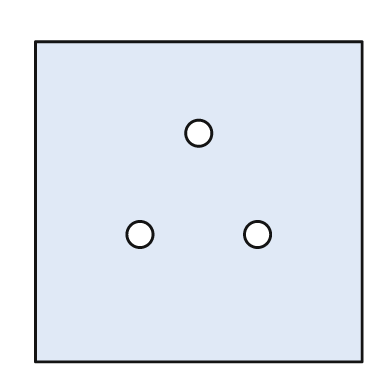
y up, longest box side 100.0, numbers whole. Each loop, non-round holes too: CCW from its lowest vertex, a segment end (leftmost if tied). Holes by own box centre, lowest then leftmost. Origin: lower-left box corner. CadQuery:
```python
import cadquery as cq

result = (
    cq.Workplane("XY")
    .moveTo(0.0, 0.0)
    .lineTo(100.0, 0.0)
    .lineTo(100.0, 98.0)
    .lineTo(0.0, 98.0)
    .close()
    .moveTo(32.0, 39.0)
    .circle(4.0)
    .moveTo(68.0, 39.0)
    .circle(4.0)
    .moveTo(50.0, 70.0)
    .circle(4.0)
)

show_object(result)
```